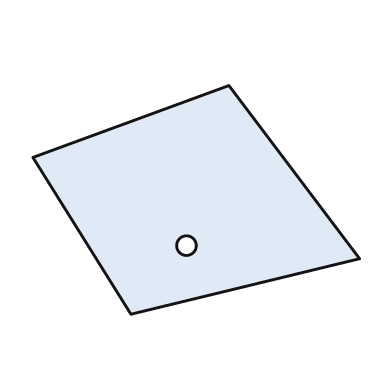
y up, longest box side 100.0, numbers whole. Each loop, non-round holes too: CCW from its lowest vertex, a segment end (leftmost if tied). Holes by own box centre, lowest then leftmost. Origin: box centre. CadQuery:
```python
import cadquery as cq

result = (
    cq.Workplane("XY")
    .moveTo(-20.0, -35.0)
    .lineTo(50.0, -18.0)
    .lineTo(10.0, 35.0)
    .lineTo(-50.0, 13.0)
    .close()
    .moveTo(-3.0, -14.0)
    .circle(3.0)
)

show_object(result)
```